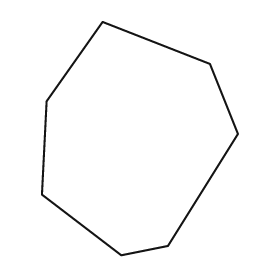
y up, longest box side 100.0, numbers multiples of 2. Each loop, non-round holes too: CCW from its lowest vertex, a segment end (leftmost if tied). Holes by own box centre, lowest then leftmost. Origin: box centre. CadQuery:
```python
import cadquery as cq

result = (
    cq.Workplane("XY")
    .moveTo(-8.0, -50.0)
    .lineTo(12.0, -46.0)
    .lineTo(42.0, 2.0)
    .lineTo(30.0, 32.0)
    .lineTo(-16.0, 50.0)
    .lineTo(-40.0, 16.0)
    .lineTo(-42.0, -24.0)
    .close()
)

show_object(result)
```